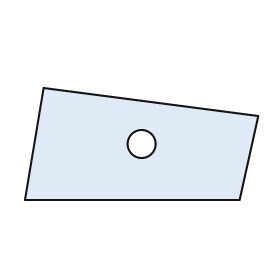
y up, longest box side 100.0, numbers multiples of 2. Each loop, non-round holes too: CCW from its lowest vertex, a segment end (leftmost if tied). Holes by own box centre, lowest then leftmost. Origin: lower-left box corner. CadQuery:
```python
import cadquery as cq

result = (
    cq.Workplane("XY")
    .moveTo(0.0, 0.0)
    .lineTo(92.0, 0.0)
    .lineTo(100.0, 36.0)
    .lineTo(8.0, 48.0)
    .close()
    .moveTo(50.0, 24.0)
    .circle(6.0)
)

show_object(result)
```